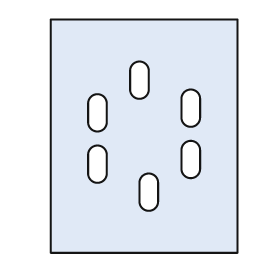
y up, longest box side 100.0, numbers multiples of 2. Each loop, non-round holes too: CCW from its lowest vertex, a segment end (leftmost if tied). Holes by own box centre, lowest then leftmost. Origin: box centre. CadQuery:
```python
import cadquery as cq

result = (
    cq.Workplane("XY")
    .moveTo(-40.0, -50.0)
    .lineTo(40.0, -50.0)
    .lineTo(40.0, 50.0)
    .lineTo(-40.0, 50.0)
    .close()
    .moveTo(-2.0, -28.0)
    .threePointArc((2.0, -32.0), (6.0, -28.0))
    .lineTo(6.0, -20.0)
    .threePointArc((2.0, -16.0), (-2.0, -20.0))
    .close()
    .moveTo(-24.0, -16.0)
    .threePointArc((-20.0, -20.0), (-16.0, -16.0))
    .lineTo(-16.0, -8.0)
    .threePointArc((-20.0, -4.0), (-24.0, -8.0))
    .close()
    .moveTo(16.0, -14.0)
    .threePointArc((20.0, -18.0), (24.0, -14.0))
    .lineTo(24.0, -6.0)
    .threePointArc((20.0, -2.0), (16.0, -6.0))
    .close()
    .moveTo(-24.0, 6.0)
    .threePointArc((-20.0, 2.0), (-16.0, 6.0))
    .lineTo(-16.0, 14.0)
    .threePointArc((-20.0, 18.0), (-24.0, 14.0))
    .close()
    .moveTo(16.0, 8.0)
    .threePointArc((20.0, 4.0), (24.0, 8.0))
    .lineTo(24.0, 16.0)
    .threePointArc((20.0, 20.0), (16.0, 16.0))
    .close()
    .moveTo(-6.0, 20.0)
    .threePointArc((-2.0, 16.0), (2.0, 20.0))
    .lineTo(2.0, 28.0)
    .threePointArc((-2.0, 32.0), (-6.0, 28.0))
    .close()
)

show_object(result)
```